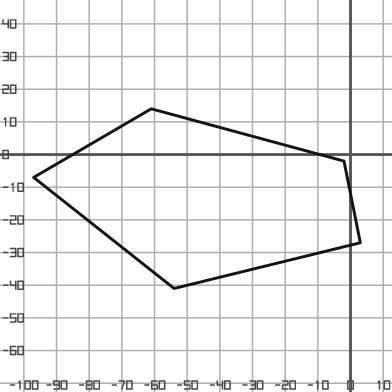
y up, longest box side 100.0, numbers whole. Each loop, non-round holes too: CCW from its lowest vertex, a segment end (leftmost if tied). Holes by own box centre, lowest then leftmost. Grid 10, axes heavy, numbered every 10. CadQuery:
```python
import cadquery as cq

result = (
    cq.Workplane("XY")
    .moveTo(-54.0, -41.0)
    .lineTo(3.0, -27.0)
    .lineTo(-2.0, -2.0)
    .lineTo(-61.0, 14.0)
    .lineTo(-97.0, -7.0)
    .close()
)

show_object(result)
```